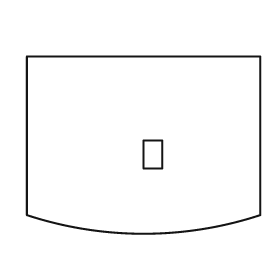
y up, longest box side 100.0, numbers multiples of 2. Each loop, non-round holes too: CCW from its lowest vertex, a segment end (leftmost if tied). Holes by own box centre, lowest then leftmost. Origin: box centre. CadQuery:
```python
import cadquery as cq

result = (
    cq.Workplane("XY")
    .moveTo(-50.0, -30.0)
    .threePointArc((0.0, -38.0), (50.0, -30.0))
    .lineTo(50.0, 38.0)
    .lineTo(-50.0, 38.0)
    .close()
    .moveTo(0.0, -10.0)
    .lineTo(8.0, -10.0)
    .lineTo(8.0, 2.0)
    .lineTo(0.0, 2.0)
    .close()
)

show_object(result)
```